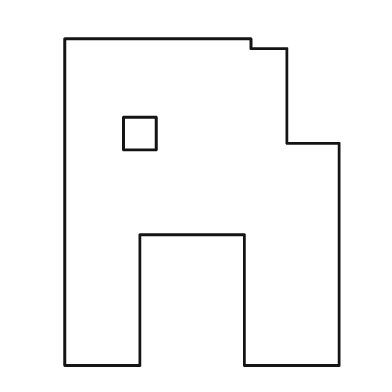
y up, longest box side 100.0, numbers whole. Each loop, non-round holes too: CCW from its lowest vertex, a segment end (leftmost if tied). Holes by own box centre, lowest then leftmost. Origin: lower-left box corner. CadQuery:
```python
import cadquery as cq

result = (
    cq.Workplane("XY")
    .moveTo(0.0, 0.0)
    .lineTo(23.0, 0.0)
    .lineTo(23.0, 40.0)
    .lineTo(55.0, 40.0)
    .lineTo(55.0, 0.0)
    .lineTo(84.0, 0.0)
    .lineTo(84.0, 68.0)
    .lineTo(68.0, 68.0)
    .lineTo(68.0, 97.0)
    .lineTo(57.0, 97.0)
    .lineTo(57.0, 100.0)
    .lineTo(0.0, 100.0)
    .close()
    .moveTo(18.0, 66.0)
    .lineTo(28.0, 66.0)
    .lineTo(28.0, 76.0)
    .lineTo(18.0, 76.0)
    .close()
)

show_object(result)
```